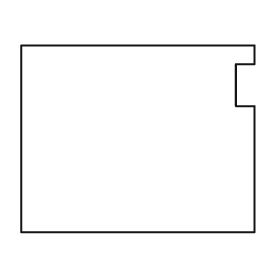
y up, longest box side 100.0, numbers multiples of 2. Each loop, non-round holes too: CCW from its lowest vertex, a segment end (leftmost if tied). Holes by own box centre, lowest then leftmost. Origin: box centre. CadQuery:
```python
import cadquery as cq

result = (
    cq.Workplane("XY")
    .moveTo(-50.0, -40.0)
    .lineTo(50.0, -40.0)
    .lineTo(50.0, 14.0)
    .lineTo(42.0, 14.0)
    .lineTo(42.0, 32.0)
    .lineTo(50.0, 32.0)
    .lineTo(50.0, 40.0)
    .lineTo(-50.0, 40.0)
    .close()
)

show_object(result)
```